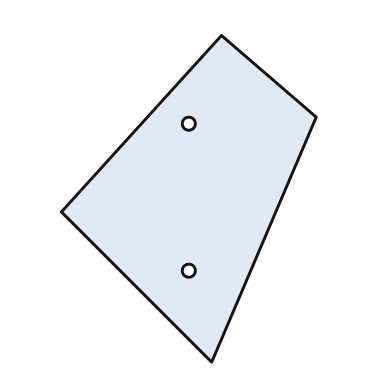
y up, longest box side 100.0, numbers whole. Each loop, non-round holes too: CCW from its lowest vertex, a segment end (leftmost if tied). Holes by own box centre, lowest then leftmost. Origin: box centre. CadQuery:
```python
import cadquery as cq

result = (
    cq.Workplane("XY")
    .moveTo(7.0, -50.0)
    .lineTo(39.0, 25.0)
    .lineTo(10.0, 50.0)
    .lineTo(-39.0, -4.0)
    .close()
    .moveTo(0.0, -22.0)
    .circle(2.0)
    .moveTo(0.0, 23.0)
    .circle(2.0)
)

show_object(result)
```